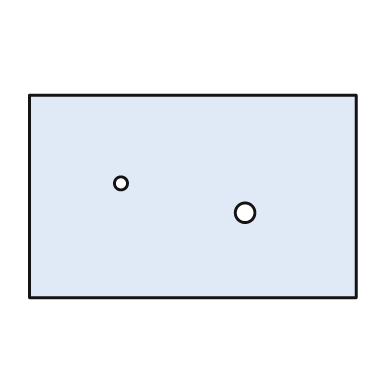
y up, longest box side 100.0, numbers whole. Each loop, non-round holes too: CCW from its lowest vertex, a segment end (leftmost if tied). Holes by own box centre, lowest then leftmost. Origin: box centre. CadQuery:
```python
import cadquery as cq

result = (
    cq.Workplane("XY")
    .moveTo(-50.0, -31.0)
    .lineTo(50.0, -31.0)
    .lineTo(50.0, 31.0)
    .lineTo(-50.0, 31.0)
    .close()
    .moveTo(16.0, -5.0)
    .circle(3.0)
    .moveTo(-22.0, 4.0)
    .circle(2.0)
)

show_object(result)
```